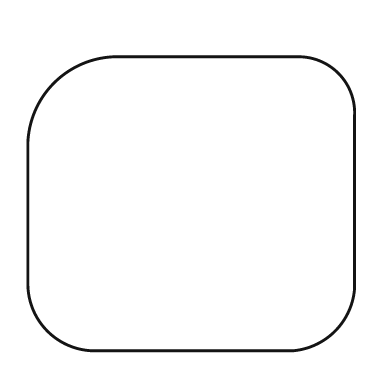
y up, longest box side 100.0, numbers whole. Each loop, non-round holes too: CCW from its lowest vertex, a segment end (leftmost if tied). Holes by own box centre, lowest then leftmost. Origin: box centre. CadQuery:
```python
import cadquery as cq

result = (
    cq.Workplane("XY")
    .moveTo(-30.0, -45.0)
    .lineTo(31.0, -45.0)
    .threePointArc((44.0, -39.0), (50.0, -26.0))
    .lineTo(50.0, 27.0)
    .threePointArc((45.0, 40.0), (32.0, 45.0))
    .lineTo(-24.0, 45.0)
    .threePointArc((-42.0, 37.0), (-50.0, 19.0))
    .lineTo(-50.0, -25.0)
    .threePointArc((-44.0, -39.0), (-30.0, -45.0))
    .close()
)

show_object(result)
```